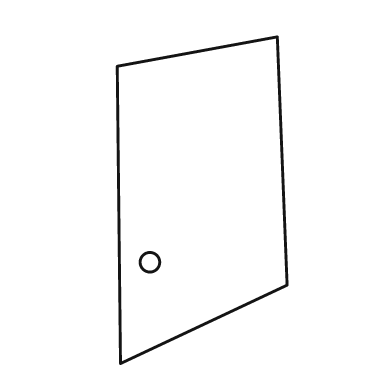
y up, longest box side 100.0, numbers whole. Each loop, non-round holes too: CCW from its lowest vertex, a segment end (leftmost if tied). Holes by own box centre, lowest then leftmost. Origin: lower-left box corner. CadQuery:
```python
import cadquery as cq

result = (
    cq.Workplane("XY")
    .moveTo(1.0, 0.0)
    .lineTo(52.0, 24.0)
    .lineTo(49.0, 100.0)
    .lineTo(0.0, 91.0)
    .close()
    .moveTo(10.0, 31.0)
    .circle(3.0)
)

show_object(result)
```